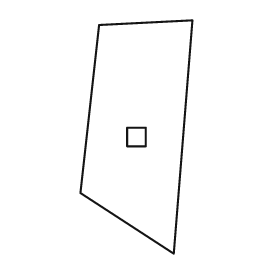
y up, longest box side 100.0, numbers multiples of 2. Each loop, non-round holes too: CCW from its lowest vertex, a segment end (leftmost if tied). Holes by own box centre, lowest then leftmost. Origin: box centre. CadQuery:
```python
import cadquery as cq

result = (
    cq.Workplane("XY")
    .moveTo(16.0, -50.0)
    .lineTo(24.0, 50.0)
    .lineTo(-16.0, 48.0)
    .lineTo(-24.0, -24.0)
    .close()
    .moveTo(-4.0, -4.0)
    .lineTo(4.0, -4.0)
    .lineTo(4.0, 4.0)
    .lineTo(-4.0, 4.0)
    .close()
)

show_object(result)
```